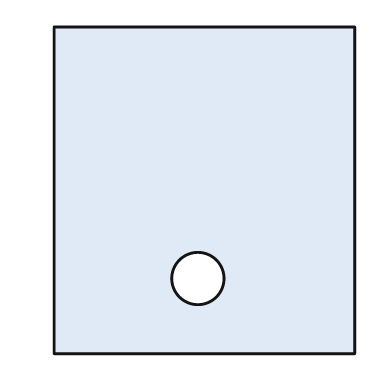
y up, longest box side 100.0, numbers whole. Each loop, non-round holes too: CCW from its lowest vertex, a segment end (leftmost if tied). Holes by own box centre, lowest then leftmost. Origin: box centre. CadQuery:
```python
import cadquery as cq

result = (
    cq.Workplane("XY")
    .moveTo(-46.0, -50.0)
    .lineTo(46.0, -50.0)
    .lineTo(46.0, 50.0)
    .lineTo(-46.0, 50.0)
    .close()
    .moveTo(-2.0, -27.0)
    .circle(8.0)
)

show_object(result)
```